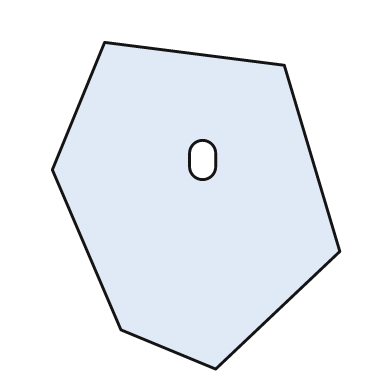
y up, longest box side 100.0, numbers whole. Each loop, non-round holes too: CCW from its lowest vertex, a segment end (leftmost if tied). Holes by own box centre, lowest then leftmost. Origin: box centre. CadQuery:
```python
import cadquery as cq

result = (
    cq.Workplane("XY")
    .moveTo(6.0, -50.0)
    .lineTo(44.0, -14.0)
    .lineTo(27.0, 43.0)
    .lineTo(-28.0, 50.0)
    .lineTo(-44.0, 11.0)
    .lineTo(-23.0, -38.0)
    .close()
    .moveTo(-2.0, 12.0)
    .threePointArc((2.0, 8.0), (6.0, 12.0))
    .lineTo(6.0, 16.0)
    .threePointArc((2.0, 20.0), (-2.0, 16.0))
    .close()
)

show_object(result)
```